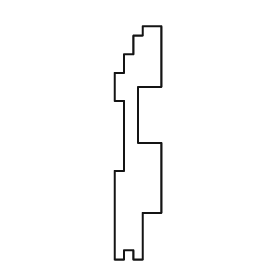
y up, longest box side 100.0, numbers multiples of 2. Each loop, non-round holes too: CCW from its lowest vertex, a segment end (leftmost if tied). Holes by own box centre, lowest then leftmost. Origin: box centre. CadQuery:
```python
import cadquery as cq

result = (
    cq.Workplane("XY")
    .moveTo(-10.0, -50.0)
    .lineTo(-6.0, -50.0)
    .lineTo(-6.0, -46.0)
    .lineTo(-2.0, -46.0)
    .lineTo(-2.0, -50.0)
    .lineTo(2.0, -50.0)
    .lineTo(2.0, -30.0)
    .lineTo(10.0, -30.0)
    .lineTo(10.0, 0.0)
    .lineTo(0.0, 0.0)
    .lineTo(0.0, 24.0)
    .lineTo(10.0, 24.0)
    .lineTo(10.0, 50.0)
    .lineTo(2.0, 50.0)
    .lineTo(2.0, 46.0)
    .lineTo(-2.0, 46.0)
    .lineTo(-2.0, 38.0)
    .lineTo(-6.0, 38.0)
    .lineTo(-6.0, 30.0)
    .lineTo(-10.0, 30.0)
    .lineTo(-10.0, 18.0)
    .lineTo(-6.0, 18.0)
    .lineTo(-6.0, -12.0)
    .lineTo(-10.0, -12.0)
    .close()
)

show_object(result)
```